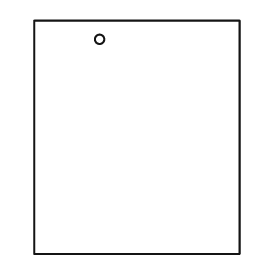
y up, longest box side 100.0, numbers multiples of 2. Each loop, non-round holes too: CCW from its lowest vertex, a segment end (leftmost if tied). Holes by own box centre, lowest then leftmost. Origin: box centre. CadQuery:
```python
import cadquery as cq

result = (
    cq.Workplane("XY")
    .moveTo(-44.0, -50.0)
    .lineTo(44.0, -50.0)
    .lineTo(44.0, 50.0)
    .lineTo(-44.0, 50.0)
    .close()
    .moveTo(-16.0, 42.0)
    .circle(2.0)
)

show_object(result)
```